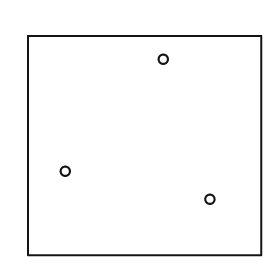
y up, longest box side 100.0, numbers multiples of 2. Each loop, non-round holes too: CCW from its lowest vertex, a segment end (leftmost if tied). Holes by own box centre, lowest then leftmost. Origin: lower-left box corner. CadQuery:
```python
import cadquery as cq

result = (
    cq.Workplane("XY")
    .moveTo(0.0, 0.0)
    .lineTo(100.0, 0.0)
    .lineTo(100.0, 94.0)
    .lineTo(0.0, 94.0)
    .close()
    .moveTo(78.0, 24.0)
    .circle(2.0)
    .moveTo(16.0, 36.0)
    .circle(2.0)
    .moveTo(58.0, 84.0)
    .circle(2.0)
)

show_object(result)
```